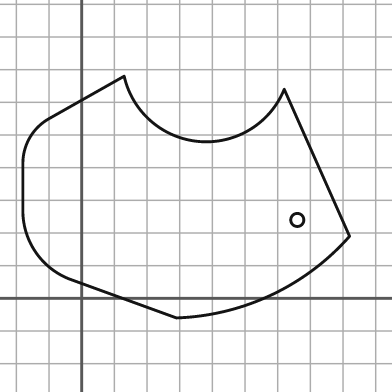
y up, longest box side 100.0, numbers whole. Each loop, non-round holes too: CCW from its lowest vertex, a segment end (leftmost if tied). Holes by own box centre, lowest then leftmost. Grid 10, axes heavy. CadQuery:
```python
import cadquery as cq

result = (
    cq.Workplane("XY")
    .moveTo(29.0, -6.0)
    .threePointArc((58.0, 1.0), (82.0, 19.0))
    .lineTo(62.0, 64.0)
    .threePointArc((36.0, 48.0), (13.0, 68.0))
    .lineTo(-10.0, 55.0)
    .threePointArc((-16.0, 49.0), (-18.0, 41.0))
    .lineTo(-18.0, 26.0)
    .threePointArc((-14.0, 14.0), (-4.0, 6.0))
    .close()
    .moveTo(66.0, 24.0)
    .circle(2.0)
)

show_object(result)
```